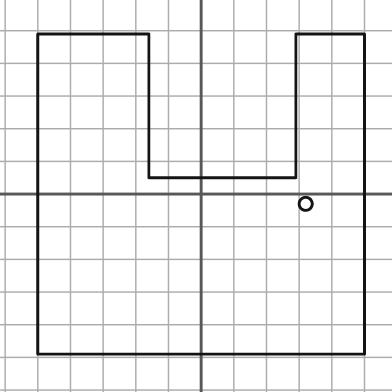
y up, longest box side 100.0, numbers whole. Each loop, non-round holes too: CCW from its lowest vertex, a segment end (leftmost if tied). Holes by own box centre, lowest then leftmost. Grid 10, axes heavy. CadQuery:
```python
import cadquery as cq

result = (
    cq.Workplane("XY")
    .moveTo(-50.0, -49.0)
    .lineTo(50.0, -49.0)
    .lineTo(50.0, 49.0)
    .lineTo(29.0, 49.0)
    .lineTo(29.0, 5.0)
    .lineTo(-16.0, 5.0)
    .lineTo(-16.0, 49.0)
    .lineTo(-50.0, 49.0)
    .close()
    .moveTo(32.0, -3.0)
    .circle(2.0)
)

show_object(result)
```